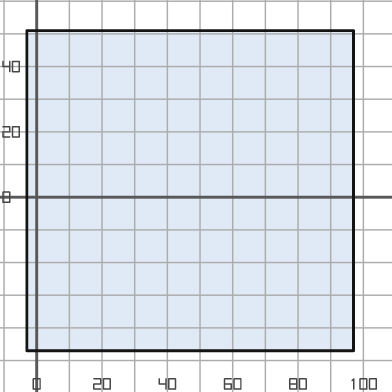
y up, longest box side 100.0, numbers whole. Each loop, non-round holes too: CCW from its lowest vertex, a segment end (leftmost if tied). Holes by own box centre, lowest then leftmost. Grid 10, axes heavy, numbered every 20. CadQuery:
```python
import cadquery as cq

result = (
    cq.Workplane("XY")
    .moveTo(-3.0, -47.0)
    .lineTo(97.0, -47.0)
    .lineTo(97.0, 51.0)
    .lineTo(-3.0, 51.0)
    .close()
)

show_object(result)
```